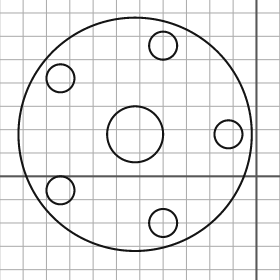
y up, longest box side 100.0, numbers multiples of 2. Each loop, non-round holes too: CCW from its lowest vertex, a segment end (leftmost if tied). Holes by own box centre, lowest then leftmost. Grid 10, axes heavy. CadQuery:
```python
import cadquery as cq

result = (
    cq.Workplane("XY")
    .moveTo(-52.0, 18.0)
    .circle(50.0)
    .moveTo(-40.0, -20.0)
    .circle(6.0)
    .moveTo(-84.0, -6.0)
    .circle(6.0)
    .moveTo(-52.0, 18.0)
    .circle(12.0)
    .moveTo(-12.0, 18.0)
    .circle(6.0)
    .moveTo(-84.0, 42.0)
    .circle(6.0)
    .moveTo(-40.0, 56.0)
    .circle(6.0)
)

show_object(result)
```